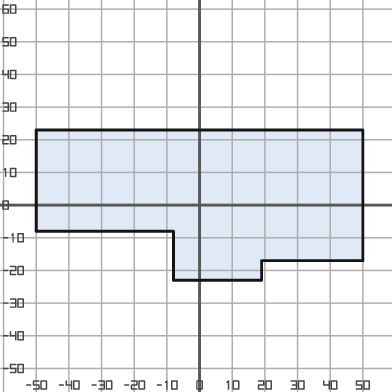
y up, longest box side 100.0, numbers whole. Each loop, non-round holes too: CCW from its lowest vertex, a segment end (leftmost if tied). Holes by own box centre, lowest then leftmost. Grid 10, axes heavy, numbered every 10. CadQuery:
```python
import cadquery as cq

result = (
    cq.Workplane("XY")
    .moveTo(-8.0, -23.0)
    .lineTo(19.0, -23.0)
    .lineTo(19.0, -17.0)
    .lineTo(50.0, -17.0)
    .lineTo(50.0, 23.0)
    .lineTo(-50.0, 23.0)
    .lineTo(-50.0, -8.0)
    .lineTo(-8.0, -8.0)
    .close()
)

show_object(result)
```